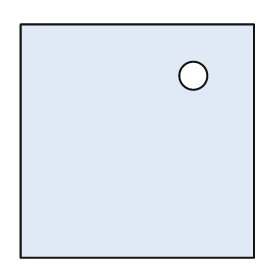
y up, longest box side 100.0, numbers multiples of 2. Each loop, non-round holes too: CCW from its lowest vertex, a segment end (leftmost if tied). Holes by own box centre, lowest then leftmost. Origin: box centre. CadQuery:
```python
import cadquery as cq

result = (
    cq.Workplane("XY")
    .moveTo(-50.0, -50.0)
    .lineTo(50.0, -50.0)
    .lineTo(50.0, 50.0)
    .lineTo(-50.0, 50.0)
    .close()
    .moveTo(24.0, 28.0)
    .circle(6.0)
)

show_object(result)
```